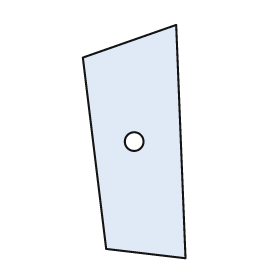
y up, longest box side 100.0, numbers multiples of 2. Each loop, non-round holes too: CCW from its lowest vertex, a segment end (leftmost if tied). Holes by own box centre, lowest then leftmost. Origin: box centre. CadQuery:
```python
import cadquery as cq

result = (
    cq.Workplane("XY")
    .moveTo(22.0, -50.0)
    .lineTo(18.0, 50.0)
    .lineTo(-22.0, 36.0)
    .lineTo(-12.0, -46.0)
    .close()
    .moveTo(0.0, 0.0)
    .circle(4.0)
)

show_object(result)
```